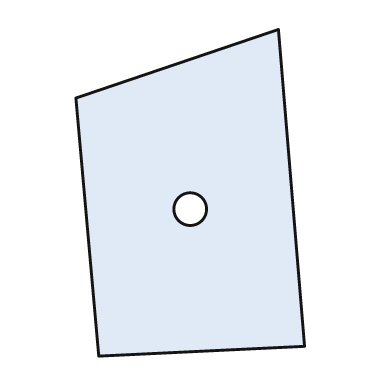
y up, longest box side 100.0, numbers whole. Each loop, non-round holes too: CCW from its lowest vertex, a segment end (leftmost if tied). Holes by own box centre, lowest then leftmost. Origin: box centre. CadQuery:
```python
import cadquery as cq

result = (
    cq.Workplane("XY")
    .moveTo(-28.0, -50.0)
    .lineTo(35.0, -47.0)
    .lineTo(27.0, 50.0)
    .lineTo(-35.0, 29.0)
    .close()
    .moveTo(0.0, -5.0)
    .circle(5.0)
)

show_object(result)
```